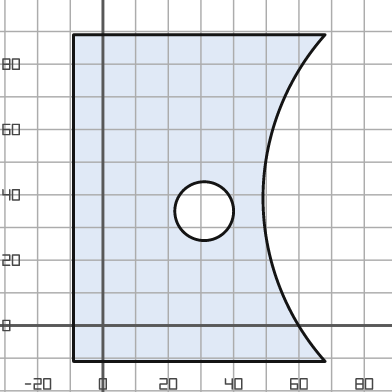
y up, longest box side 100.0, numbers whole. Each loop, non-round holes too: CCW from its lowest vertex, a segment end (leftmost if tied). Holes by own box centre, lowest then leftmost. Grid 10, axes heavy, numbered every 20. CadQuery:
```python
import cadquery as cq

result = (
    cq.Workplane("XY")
    .moveTo(-9.0, -11.0)
    .lineTo(68.0, -11.0)
    .threePointArc((49.0, 39.0), (68.0, 89.0))
    .lineTo(-9.0, 89.0)
    .close()
    .moveTo(31.0, 35.0)
    .circle(9.0)
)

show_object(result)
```